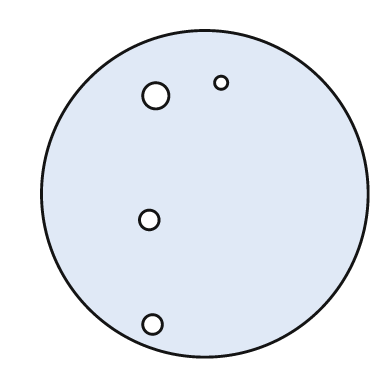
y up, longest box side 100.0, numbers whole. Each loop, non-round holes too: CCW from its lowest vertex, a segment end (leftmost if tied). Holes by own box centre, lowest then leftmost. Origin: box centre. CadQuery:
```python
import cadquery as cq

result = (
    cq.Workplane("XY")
    .moveTo(0.0, 0.0)
    .circle(50.0)
    .moveTo(-16.0, -40.0)
    .circle(3.0)
    .moveTo(-17.0, -8.0)
    .circle(3.0)
    .moveTo(-15.0, 30.0)
    .circle(4.0)
    .moveTo(5.0, 34.0)
    .circle(2.0)
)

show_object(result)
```